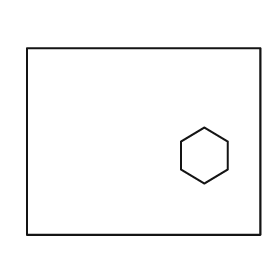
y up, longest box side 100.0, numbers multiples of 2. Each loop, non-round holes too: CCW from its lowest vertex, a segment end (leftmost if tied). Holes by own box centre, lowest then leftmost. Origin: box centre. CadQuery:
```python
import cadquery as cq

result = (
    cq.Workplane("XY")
    .moveTo(-50.0, -40.0)
    .lineTo(50.0, -40.0)
    .lineTo(50.0, 40.0)
    .lineTo(-50.0, 40.0)
    .close()
    .moveTo(26.0, -18.0)
    .lineTo(36.0, -12.0)
    .lineTo(36.0, 0.0)
    .lineTo(26.0, 6.0)
    .lineTo(16.0, 0.0)
    .lineTo(16.0, -12.0)
    .close()
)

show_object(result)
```